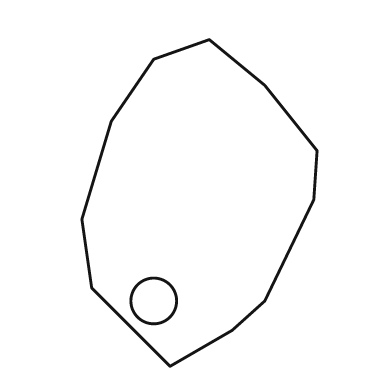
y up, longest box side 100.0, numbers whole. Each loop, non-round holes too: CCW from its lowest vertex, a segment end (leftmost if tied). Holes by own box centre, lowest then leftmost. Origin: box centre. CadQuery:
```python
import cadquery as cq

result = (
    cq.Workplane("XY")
    .moveTo(-9.0, -50.0)
    .lineTo(10.0, -39.0)
    .lineTo(20.0, -30.0)
    .lineTo(35.0, 1.0)
    .lineTo(36.0, 16.0)
    .lineTo(20.0, 36.0)
    .lineTo(3.0, 50.0)
    .lineTo(-14.0, 44.0)
    .lineTo(-27.0, 25.0)
    .lineTo(-36.0, -5.0)
    .lineTo(-33.0, -26.0)
    .close()
    .moveTo(-14.0, -30.0)
    .circle(7.0)
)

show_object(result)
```